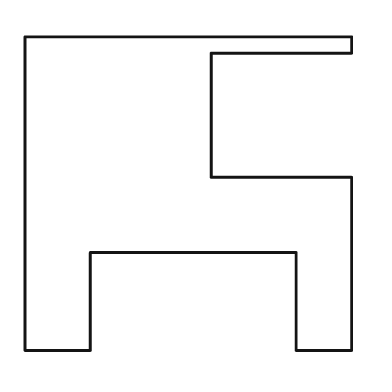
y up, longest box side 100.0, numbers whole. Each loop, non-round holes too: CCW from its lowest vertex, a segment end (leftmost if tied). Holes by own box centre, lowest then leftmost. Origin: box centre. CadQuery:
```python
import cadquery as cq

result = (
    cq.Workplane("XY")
    .moveTo(-50.0, -48.0)
    .lineTo(-30.0, -48.0)
    .lineTo(-30.0, -18.0)
    .lineTo(33.0, -18.0)
    .lineTo(33.0, -48.0)
    .lineTo(50.0, -48.0)
    .lineTo(50.0, 5.0)
    .lineTo(7.0, 5.0)
    .lineTo(7.0, 43.0)
    .lineTo(50.0, 43.0)
    .lineTo(50.0, 48.0)
    .lineTo(-50.0, 48.0)
    .close()
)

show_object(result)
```